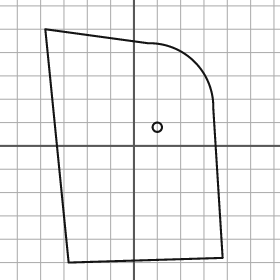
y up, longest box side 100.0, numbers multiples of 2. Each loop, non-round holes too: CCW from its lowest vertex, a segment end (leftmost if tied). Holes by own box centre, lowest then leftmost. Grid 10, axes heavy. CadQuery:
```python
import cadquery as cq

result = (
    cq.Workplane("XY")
    .moveTo(-28.0, -50.0)
    .lineTo(38.0, -48.0)
    .lineTo(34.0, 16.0)
    .threePointArc((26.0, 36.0), (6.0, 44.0))
    .lineTo(-38.0, 50.0)
    .close()
    .moveTo(10.0, 8.0)
    .circle(2.0)
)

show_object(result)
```